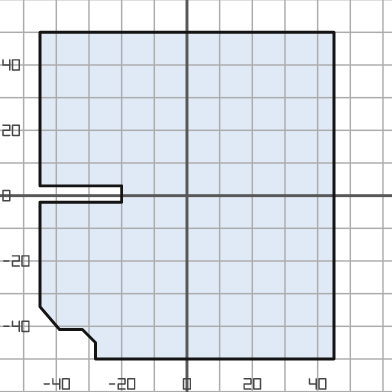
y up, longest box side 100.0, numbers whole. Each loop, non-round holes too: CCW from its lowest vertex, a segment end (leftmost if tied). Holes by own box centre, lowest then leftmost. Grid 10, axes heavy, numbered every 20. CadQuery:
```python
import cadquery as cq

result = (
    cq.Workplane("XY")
    .moveTo(-28.0, -50.0)
    .lineTo(45.0, -50.0)
    .lineTo(45.0, 50.0)
    .lineTo(-45.0, 50.0)
    .lineTo(-45.0, 3.0)
    .lineTo(-20.0, 3.0)
    .lineTo(-20.0, -2.0)
    .lineTo(-45.0, -2.0)
    .lineTo(-45.0, -34.0)
    .lineTo(-39.0, -41.0)
    .lineTo(-32.0, -41.0)
    .lineTo(-28.0, -45.0)
    .close()
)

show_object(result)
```